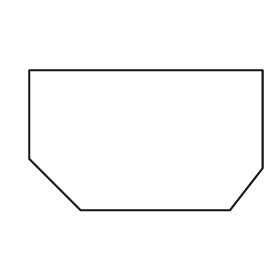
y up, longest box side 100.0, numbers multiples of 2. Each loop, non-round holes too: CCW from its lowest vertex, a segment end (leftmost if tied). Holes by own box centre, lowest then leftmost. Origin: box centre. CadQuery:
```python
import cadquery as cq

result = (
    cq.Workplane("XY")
    .moveTo(-28.0, -30.0)
    .lineTo(36.0, -30.0)
    .lineTo(50.0, -12.0)
    .lineTo(50.0, 30.0)
    .lineTo(-50.0, 30.0)
    .lineTo(-50.0, -8.0)
    .close()
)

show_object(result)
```